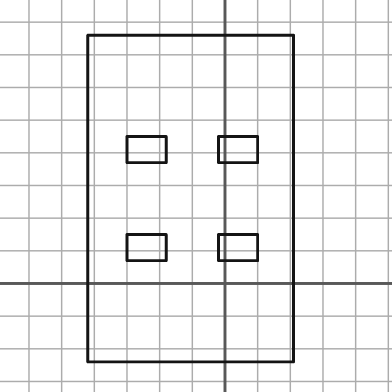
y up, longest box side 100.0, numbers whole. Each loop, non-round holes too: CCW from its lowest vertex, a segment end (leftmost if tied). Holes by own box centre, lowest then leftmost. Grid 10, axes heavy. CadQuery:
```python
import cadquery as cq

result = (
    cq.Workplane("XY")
    .moveTo(-42.0, -24.0)
    .lineTo(21.0, -24.0)
    .lineTo(21.0, 76.0)
    .lineTo(-42.0, 76.0)
    .close()
    .moveTo(-30.0, 7.0)
    .lineTo(-18.0, 7.0)
    .lineTo(-18.0, 15.0)
    .lineTo(-30.0, 15.0)
    .close()
    .moveTo(-2.0, 7.0)
    .lineTo(10.0, 7.0)
    .lineTo(10.0, 15.0)
    .lineTo(-2.0, 15.0)
    .close()
    .moveTo(-30.0, 37.0)
    .lineTo(-18.0, 37.0)
    .lineTo(-18.0, 45.0)
    .lineTo(-30.0, 45.0)
    .close()
    .moveTo(-2.0, 37.0)
    .lineTo(10.0, 37.0)
    .lineTo(10.0, 45.0)
    .lineTo(-2.0, 45.0)
    .close()
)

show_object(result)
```